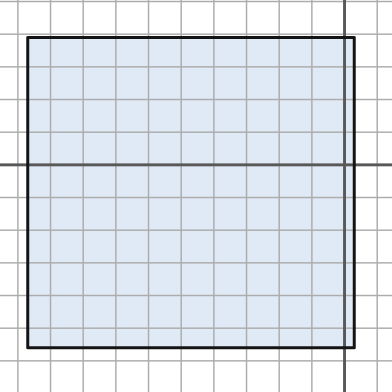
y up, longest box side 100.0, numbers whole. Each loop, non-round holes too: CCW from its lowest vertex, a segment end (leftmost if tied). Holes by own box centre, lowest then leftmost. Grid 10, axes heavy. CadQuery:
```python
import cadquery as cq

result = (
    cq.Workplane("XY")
    .moveTo(-97.0, -56.0)
    .lineTo(3.0, -56.0)
    .lineTo(3.0, 39.0)
    .lineTo(-97.0, 39.0)
    .close()
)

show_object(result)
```